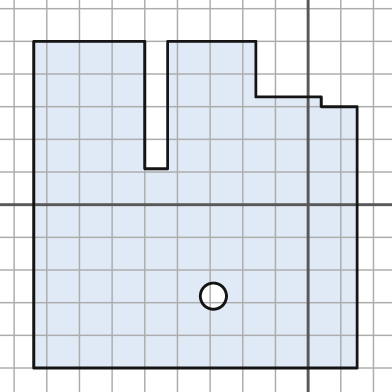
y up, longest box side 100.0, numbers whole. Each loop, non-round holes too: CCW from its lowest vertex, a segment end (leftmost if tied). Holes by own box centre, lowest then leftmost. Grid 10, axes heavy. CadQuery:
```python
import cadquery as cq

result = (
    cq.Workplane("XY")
    .moveTo(-84.0, -50.0)
    .lineTo(15.0, -50.0)
    .lineTo(15.0, 30.0)
    .lineTo(4.0, 30.0)
    .lineTo(4.0, 33.0)
    .lineTo(-16.0, 33.0)
    .lineTo(-16.0, 50.0)
    .lineTo(-43.0, 50.0)
    .lineTo(-43.0, 11.0)
    .lineTo(-50.0, 11.0)
    .lineTo(-50.0, 50.0)
    .lineTo(-84.0, 50.0)
    .close()
    .moveTo(-29.0, -28.0)
    .circle(4.0)
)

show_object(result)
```